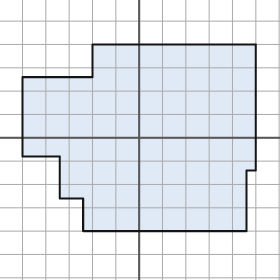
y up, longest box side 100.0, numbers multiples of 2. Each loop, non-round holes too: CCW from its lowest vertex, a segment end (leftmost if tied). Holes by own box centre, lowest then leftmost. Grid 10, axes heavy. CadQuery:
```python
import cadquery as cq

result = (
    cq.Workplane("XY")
    .moveTo(-24.0, -40.0)
    .lineTo(46.0, -40.0)
    .lineTo(46.0, -14.0)
    .lineTo(50.0, -14.0)
    .lineTo(50.0, 40.0)
    .lineTo(-20.0, 40.0)
    .lineTo(-20.0, 26.0)
    .lineTo(-50.0, 26.0)
    .lineTo(-50.0, -8.0)
    .lineTo(-34.0, -8.0)
    .lineTo(-34.0, -26.0)
    .lineTo(-24.0, -26.0)
    .close()
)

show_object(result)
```